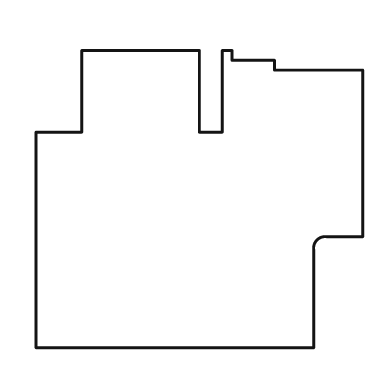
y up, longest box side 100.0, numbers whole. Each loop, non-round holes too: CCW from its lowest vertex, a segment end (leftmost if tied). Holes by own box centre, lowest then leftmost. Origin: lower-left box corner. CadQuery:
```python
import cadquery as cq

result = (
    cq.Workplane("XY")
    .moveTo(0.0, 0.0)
    .lineTo(85.0, 0.0)
    .lineTo(85.0, 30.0)
    .threePointArc((86.0, 33.0), (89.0, 34.0))
    .lineTo(100.0, 34.0)
    .lineTo(100.0, 85.0)
    .lineTo(73.0, 85.0)
    .lineTo(73.0, 88.0)
    .lineTo(60.0, 88.0)
    .lineTo(60.0, 91.0)
    .lineTo(57.0, 91.0)
    .lineTo(57.0, 66.0)
    .lineTo(50.0, 66.0)
    .lineTo(50.0, 91.0)
    .lineTo(14.0, 91.0)
    .lineTo(14.0, 66.0)
    .lineTo(0.0, 66.0)
    .close()
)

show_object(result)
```